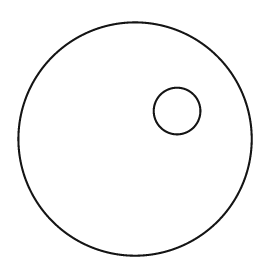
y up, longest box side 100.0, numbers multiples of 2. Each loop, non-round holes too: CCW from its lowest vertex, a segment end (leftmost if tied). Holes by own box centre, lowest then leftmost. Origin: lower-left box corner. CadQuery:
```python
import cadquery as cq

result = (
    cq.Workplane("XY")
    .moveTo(50.0, 50.0)
    .circle(50.0)
    .moveTo(68.0, 62.0)
    .circle(10.0)
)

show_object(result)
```